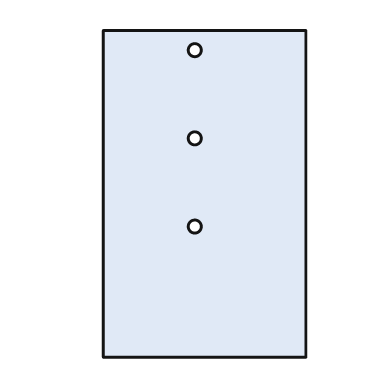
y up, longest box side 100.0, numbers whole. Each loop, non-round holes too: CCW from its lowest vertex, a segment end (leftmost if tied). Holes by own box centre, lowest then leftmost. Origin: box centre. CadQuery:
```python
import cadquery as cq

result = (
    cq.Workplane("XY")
    .moveTo(-31.0, -50.0)
    .lineTo(31.0, -50.0)
    .lineTo(31.0, 50.0)
    .lineTo(-31.0, 50.0)
    .close()
    .moveTo(-3.0, -10.0)
    .circle(2.0)
    .moveTo(-3.0, 17.0)
    .circle(2.0)
    .moveTo(-3.0, 44.0)
    .circle(2.0)
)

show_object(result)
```